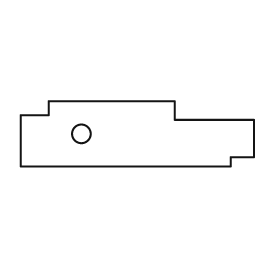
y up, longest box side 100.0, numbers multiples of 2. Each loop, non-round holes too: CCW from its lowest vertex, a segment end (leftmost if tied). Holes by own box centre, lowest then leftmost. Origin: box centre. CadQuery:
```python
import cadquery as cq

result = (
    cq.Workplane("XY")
    .moveTo(-50.0, -14.0)
    .lineTo(40.0, -14.0)
    .lineTo(40.0, -10.0)
    .lineTo(50.0, -10.0)
    .lineTo(50.0, 6.0)
    .lineTo(16.0, 6.0)
    .lineTo(16.0, 14.0)
    .lineTo(-38.0, 14.0)
    .lineTo(-38.0, 8.0)
    .lineTo(-50.0, 8.0)
    .close()
    .moveTo(-24.0, 0.0)
    .circle(4.0)
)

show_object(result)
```